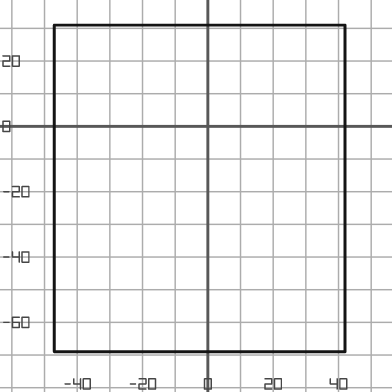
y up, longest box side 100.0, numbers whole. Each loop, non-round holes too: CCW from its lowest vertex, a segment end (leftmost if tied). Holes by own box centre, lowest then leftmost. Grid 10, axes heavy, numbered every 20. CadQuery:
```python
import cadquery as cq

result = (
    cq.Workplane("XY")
    .moveTo(-47.0, -69.0)
    .lineTo(42.0, -69.0)
    .lineTo(42.0, 31.0)
    .lineTo(-47.0, 31.0)
    .close()
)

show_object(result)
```